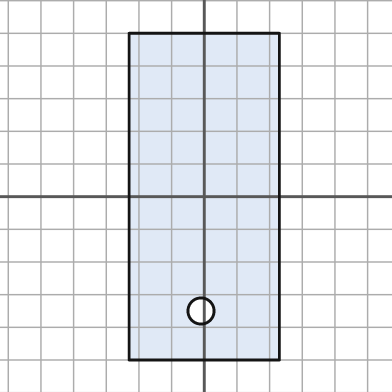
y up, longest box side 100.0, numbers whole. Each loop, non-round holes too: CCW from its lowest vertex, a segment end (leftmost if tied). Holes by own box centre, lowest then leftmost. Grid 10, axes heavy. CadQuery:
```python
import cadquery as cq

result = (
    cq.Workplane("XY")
    .moveTo(-23.0, -50.0)
    .lineTo(23.0, -50.0)
    .lineTo(23.0, 50.0)
    .lineTo(-23.0, 50.0)
    .close()
    .moveTo(-1.0, -35.0)
    .circle(4.0)
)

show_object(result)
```